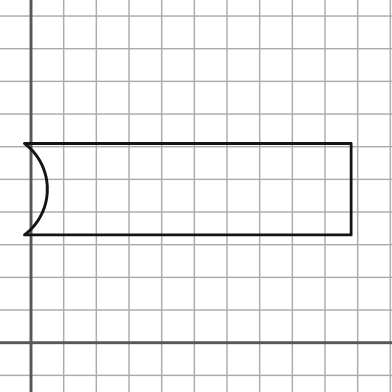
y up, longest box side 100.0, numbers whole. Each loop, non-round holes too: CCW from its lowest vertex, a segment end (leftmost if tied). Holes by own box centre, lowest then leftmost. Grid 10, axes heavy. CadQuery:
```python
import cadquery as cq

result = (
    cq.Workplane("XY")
    .moveTo(-2.0, 33.0)
    .lineTo(98.0, 33.0)
    .lineTo(98.0, 61.0)
    .lineTo(-2.0, 61.0)
    .threePointArc((5.0, 47.0), (-2.0, 33.0))
    .close()
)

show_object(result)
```